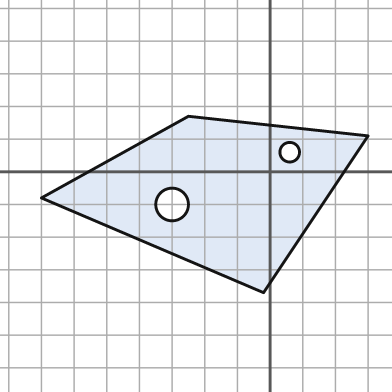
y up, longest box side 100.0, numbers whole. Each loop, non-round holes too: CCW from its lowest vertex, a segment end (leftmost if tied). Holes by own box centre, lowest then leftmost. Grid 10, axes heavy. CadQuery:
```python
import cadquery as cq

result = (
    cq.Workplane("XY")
    .moveTo(-2.0, -37.0)
    .lineTo(30.0, 11.0)
    .lineTo(-25.0, 17.0)
    .lineTo(-70.0, -8.0)
    .close()
    .moveTo(-30.0, -10.0)
    .circle(5.0)
    .moveTo(6.0, 6.0)
    .circle(3.0)
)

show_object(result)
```